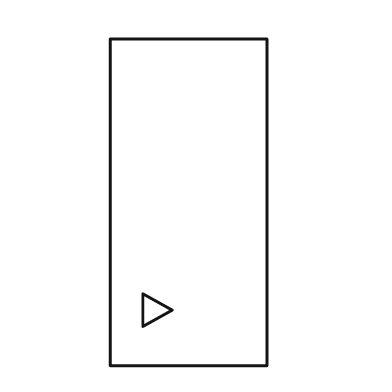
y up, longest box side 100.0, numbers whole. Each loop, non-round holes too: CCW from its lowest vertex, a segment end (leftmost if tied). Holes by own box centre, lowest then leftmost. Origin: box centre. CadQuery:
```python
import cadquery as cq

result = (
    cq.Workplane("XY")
    .moveTo(-24.0, -50.0)
    .lineTo(24.0, -50.0)
    .lineTo(24.0, 50.0)
    .lineTo(-24.0, 50.0)
    .close()
    .moveTo(-14.0, -38.0)
    .lineTo(-5.0, -33.0)
    .lineTo(-14.0, -28.0)
    .close()
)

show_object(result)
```